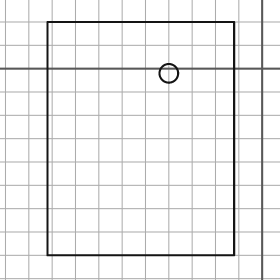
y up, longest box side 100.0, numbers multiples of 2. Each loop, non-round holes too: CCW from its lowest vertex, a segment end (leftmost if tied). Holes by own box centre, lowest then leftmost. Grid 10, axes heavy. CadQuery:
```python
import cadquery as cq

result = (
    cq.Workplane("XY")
    .moveTo(-92.0, -80.0)
    .lineTo(-12.0, -80.0)
    .lineTo(-12.0, 20.0)
    .lineTo(-92.0, 20.0)
    .close()
    .moveTo(-40.0, -2.0)
    .circle(4.0)
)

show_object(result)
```